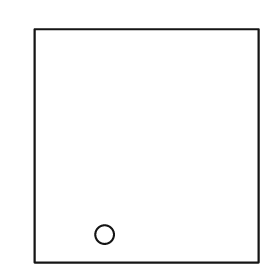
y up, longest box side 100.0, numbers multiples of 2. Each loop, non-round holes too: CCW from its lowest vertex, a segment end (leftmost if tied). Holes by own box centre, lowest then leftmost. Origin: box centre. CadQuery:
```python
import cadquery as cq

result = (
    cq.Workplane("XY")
    .moveTo(-48.0, -50.0)
    .lineTo(48.0, -50.0)
    .lineTo(48.0, 50.0)
    .lineTo(-48.0, 50.0)
    .close()
    .moveTo(-18.0, -38.0)
    .circle(4.0)
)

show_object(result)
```